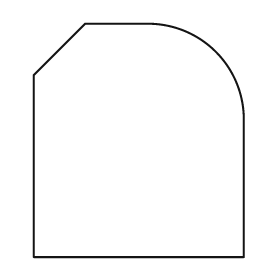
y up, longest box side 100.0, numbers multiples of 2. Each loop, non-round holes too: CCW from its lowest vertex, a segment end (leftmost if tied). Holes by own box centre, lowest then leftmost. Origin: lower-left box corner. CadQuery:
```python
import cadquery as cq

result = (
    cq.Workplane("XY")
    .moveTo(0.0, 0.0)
    .lineTo(90.0, 0.0)
    .lineTo(90.0, 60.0)
    .threePointArc((78.0, 88.0), (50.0, 100.0))
    .lineTo(22.0, 100.0)
    .lineTo(0.0, 78.0)
    .close()
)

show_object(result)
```